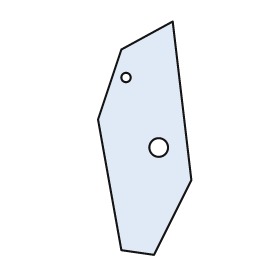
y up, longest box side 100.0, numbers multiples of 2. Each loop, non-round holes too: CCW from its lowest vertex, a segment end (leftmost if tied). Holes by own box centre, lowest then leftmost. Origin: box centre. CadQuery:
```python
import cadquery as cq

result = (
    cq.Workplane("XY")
    .moveTo(4.0, -50.0)
    .lineTo(20.0, -18.0)
    .lineTo(12.0, 50.0)
    .lineTo(-10.0, 38.0)
    .lineTo(-20.0, 8.0)
    .lineTo(-10.0, -48.0)
    .close()
    .moveTo(6.0, -4.0)
    .circle(4.0)
    .moveTo(-8.0, 26.0)
    .circle(2.0)
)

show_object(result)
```